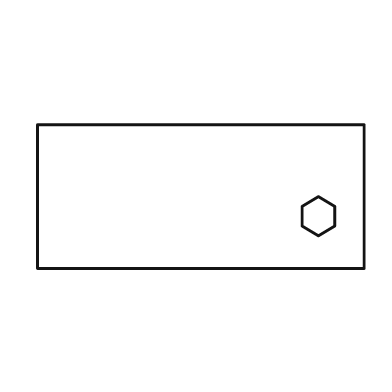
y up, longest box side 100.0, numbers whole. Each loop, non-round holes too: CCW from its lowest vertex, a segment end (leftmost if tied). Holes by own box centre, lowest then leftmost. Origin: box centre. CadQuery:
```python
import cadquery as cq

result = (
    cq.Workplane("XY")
    .moveTo(-50.0, -22.0)
    .lineTo(50.0, -22.0)
    .lineTo(50.0, 22.0)
    .lineTo(-50.0, 22.0)
    .close()
    .moveTo(36.0, -12.0)
    .lineTo(41.0, -9.0)
    .lineTo(41.0, -3.0)
    .lineTo(36.0, 0.0)
    .lineTo(31.0, -3.0)
    .lineTo(31.0, -9.0)
    .close()
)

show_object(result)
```